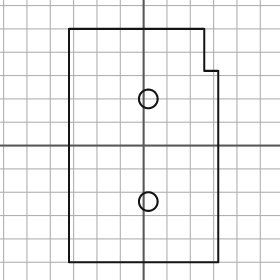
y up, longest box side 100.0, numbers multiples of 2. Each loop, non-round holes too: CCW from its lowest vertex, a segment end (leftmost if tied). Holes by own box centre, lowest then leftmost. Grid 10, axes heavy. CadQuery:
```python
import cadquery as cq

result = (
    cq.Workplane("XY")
    .moveTo(-32.0, -50.0)
    .lineTo(32.0, -50.0)
    .lineTo(32.0, 32.0)
    .lineTo(26.0, 32.0)
    .lineTo(26.0, 50.0)
    .lineTo(-32.0, 50.0)
    .close()
    .moveTo(2.0, -24.0)
    .circle(4.0)
    .moveTo(2.0, 20.0)
    .circle(4.0)
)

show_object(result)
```